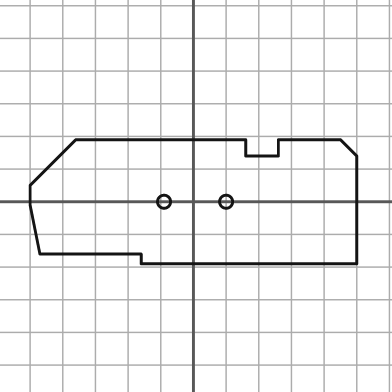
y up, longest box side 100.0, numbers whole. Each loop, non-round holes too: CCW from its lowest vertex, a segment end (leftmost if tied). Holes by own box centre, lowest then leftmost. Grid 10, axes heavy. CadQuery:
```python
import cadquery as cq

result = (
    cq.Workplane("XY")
    .moveTo(-16.0, -19.0)
    .lineTo(50.0, -19.0)
    .lineTo(50.0, 14.0)
    .lineTo(45.0, 19.0)
    .lineTo(26.0, 19.0)
    .lineTo(26.0, 14.0)
    .lineTo(16.0, 14.0)
    .lineTo(16.0, 19.0)
    .lineTo(-36.0, 19.0)
    .lineTo(-50.0, 5.0)
    .lineTo(-50.0, -1.0)
    .lineTo(-47.0, -16.0)
    .lineTo(-16.0, -16.0)
    .close()
    .moveTo(-9.0, 0.0)
    .circle(2.0)
    .moveTo(10.0, 0.0)
    .circle(2.0)
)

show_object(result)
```